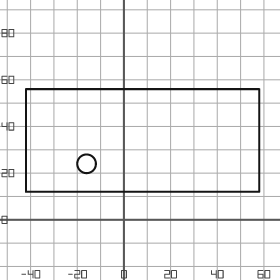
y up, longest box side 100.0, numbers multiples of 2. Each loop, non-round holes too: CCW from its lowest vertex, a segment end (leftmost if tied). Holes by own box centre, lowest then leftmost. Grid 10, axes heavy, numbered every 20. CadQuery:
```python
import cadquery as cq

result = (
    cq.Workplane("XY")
    .moveTo(-42.0, 12.0)
    .lineTo(58.0, 12.0)
    .lineTo(58.0, 56.0)
    .lineTo(-42.0, 56.0)
    .close()
    .moveTo(-16.0, 24.0)
    .circle(4.0)
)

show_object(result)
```